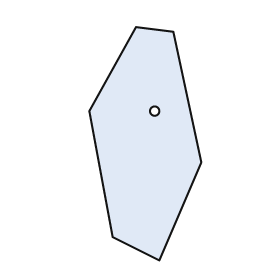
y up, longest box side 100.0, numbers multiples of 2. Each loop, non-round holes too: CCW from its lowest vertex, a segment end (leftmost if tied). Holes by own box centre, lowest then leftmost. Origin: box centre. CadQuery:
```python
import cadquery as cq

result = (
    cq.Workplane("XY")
    .moveTo(6.0, -50.0)
    .lineTo(24.0, -8.0)
    .lineTo(12.0, 48.0)
    .lineTo(-4.0, 50.0)
    .lineTo(-24.0, 14.0)
    .lineTo(-14.0, -40.0)
    .close()
    .moveTo(4.0, 14.0)
    .circle(2.0)
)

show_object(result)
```